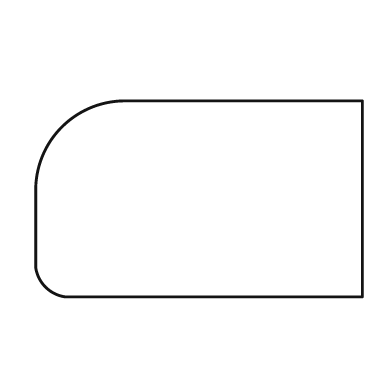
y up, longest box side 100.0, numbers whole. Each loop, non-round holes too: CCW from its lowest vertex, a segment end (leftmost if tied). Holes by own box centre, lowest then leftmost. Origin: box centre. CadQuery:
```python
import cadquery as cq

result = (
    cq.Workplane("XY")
    .moveTo(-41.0, -30.0)
    .lineTo(50.0, -30.0)
    .lineTo(50.0, 30.0)
    .lineTo(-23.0, 30.0)
    .threePointArc((-42.0, 22.0), (-50.0, 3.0))
    .lineTo(-50.0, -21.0)
    .threePointArc((-47.0, -27.0), (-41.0, -30.0))
    .close()
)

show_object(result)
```